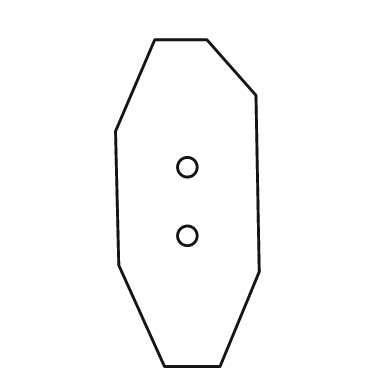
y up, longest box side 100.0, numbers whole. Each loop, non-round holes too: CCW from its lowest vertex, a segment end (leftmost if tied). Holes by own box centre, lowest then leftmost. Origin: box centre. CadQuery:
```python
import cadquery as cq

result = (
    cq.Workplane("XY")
    .moveTo(-7.0, -50.0)
    .lineTo(10.0, -50.0)
    .lineTo(22.0, -21.0)
    .lineTo(21.0, 33.0)
    .lineTo(6.0, 50.0)
    .lineTo(-10.0, 50.0)
    .lineTo(-22.0, 22.0)
    .lineTo(-21.0, -19.0)
    .close()
    .moveTo(0.0, -10.0)
    .circle(3.0)
    .moveTo(0.0, 11.0)
    .circle(3.0)
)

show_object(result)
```